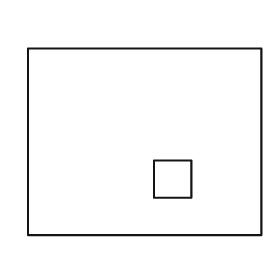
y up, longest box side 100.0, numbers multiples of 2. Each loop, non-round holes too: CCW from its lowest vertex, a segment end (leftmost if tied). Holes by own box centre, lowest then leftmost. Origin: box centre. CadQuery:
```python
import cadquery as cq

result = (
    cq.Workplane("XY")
    .moveTo(-50.0, -40.0)
    .lineTo(50.0, -40.0)
    .lineTo(50.0, 40.0)
    .lineTo(-50.0, 40.0)
    .close()
    .moveTo(4.0, -24.0)
    .lineTo(20.0, -24.0)
    .lineTo(20.0, -8.0)
    .lineTo(4.0, -8.0)
    .close()
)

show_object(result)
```